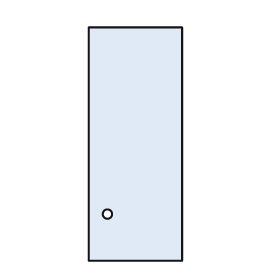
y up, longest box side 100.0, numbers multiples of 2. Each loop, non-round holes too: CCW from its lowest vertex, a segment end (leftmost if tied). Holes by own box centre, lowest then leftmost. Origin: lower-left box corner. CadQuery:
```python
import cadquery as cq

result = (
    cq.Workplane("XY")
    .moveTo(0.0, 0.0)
    .lineTo(40.0, 0.0)
    .lineTo(40.0, 100.0)
    .lineTo(0.0, 100.0)
    .close()
    .moveTo(8.0, 20.0)
    .circle(2.0)
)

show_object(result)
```